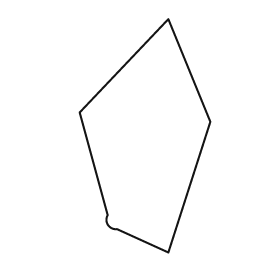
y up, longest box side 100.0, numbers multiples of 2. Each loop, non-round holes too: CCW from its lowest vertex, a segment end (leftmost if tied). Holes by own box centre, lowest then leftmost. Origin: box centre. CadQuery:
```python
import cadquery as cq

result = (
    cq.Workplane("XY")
    .moveTo(10.0, -50.0)
    .lineTo(28.0, 6.0)
    .lineTo(10.0, 50.0)
    .lineTo(-28.0, 10.0)
    .lineTo(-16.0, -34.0)
    .threePointArc((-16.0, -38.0), (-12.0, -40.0))
    .close()
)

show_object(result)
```